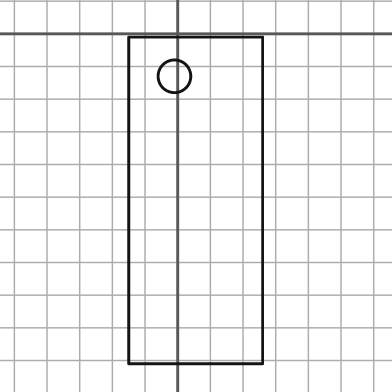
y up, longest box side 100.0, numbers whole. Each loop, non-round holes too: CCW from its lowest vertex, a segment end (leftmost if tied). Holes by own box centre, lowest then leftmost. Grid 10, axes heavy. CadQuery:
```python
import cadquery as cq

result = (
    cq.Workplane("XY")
    .moveTo(-15.0, -101.0)
    .lineTo(26.0, -101.0)
    .lineTo(26.0, -1.0)
    .lineTo(-15.0, -1.0)
    .close()
    .moveTo(-1.0, -13.0)
    .circle(5.0)
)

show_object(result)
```